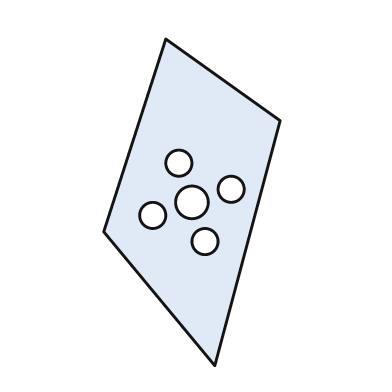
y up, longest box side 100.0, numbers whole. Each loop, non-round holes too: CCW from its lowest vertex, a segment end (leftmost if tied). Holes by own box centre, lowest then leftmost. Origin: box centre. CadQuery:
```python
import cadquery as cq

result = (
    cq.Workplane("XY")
    .moveTo(7.0, -50.0)
    .lineTo(27.0, 25.0)
    .lineTo(-8.0, 50.0)
    .lineTo(-27.0, -9.0)
    .close()
    .moveTo(4.0, -12.0)
    .circle(4.0)
    .moveTo(-12.0, -4.0)
    .circle(4.0)
    .moveTo(0.0, 0.0)
    .circle(5.0)
    .moveTo(12.0, 4.0)
    .circle(4.0)
    .moveTo(-4.0, 12.0)
    .circle(4.0)
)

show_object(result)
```